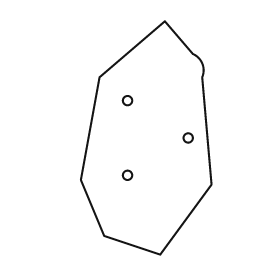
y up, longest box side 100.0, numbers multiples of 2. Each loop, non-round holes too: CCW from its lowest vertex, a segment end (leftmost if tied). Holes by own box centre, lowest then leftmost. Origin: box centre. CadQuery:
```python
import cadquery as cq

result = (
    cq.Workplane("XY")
    .moveTo(6.0, -50.0)
    .lineTo(28.0, -20.0)
    .lineTo(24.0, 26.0)
    .threePointArc((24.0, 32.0), (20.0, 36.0))
    .lineTo(8.0, 50.0)
    .lineTo(-20.0, 26.0)
    .lineTo(-28.0, -18.0)
    .lineTo(-18.0, -42.0)
    .close()
    .moveTo(-8.0, -16.0)
    .circle(2.0)
    .moveTo(18.0, 0.0)
    .circle(2.0)
    .moveTo(-8.0, 16.0)
    .circle(2.0)
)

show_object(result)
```